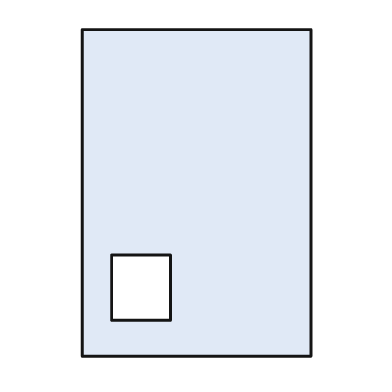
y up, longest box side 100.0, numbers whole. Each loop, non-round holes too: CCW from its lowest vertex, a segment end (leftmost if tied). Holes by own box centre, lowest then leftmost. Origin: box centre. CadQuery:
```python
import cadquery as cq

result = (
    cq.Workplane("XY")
    .moveTo(-35.0, -50.0)
    .lineTo(35.0, -50.0)
    .lineTo(35.0, 50.0)
    .lineTo(-35.0, 50.0)
    .close()
    .moveTo(-26.0, -39.0)
    .lineTo(-8.0, -39.0)
    .lineTo(-8.0, -19.0)
    .lineTo(-26.0, -19.0)
    .close()
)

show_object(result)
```